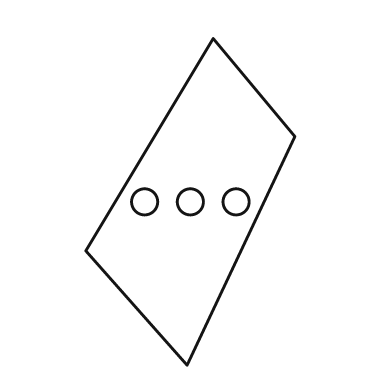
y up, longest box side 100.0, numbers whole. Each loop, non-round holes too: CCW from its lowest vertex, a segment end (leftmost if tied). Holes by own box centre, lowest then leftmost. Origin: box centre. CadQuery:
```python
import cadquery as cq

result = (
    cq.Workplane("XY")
    .moveTo(-1.0, -50.0)
    .lineTo(32.0, 20.0)
    .lineTo(7.0, 50.0)
    .lineTo(-32.0, -15.0)
    .close()
    .moveTo(-14.0, 0.0)
    .circle(4.0)
    .moveTo(0.0, 0.0)
    .circle(4.0)
    .moveTo(14.0, 0.0)
    .circle(4.0)
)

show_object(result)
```